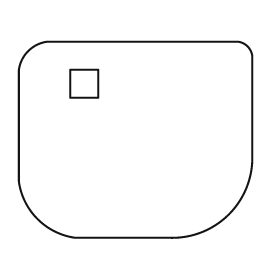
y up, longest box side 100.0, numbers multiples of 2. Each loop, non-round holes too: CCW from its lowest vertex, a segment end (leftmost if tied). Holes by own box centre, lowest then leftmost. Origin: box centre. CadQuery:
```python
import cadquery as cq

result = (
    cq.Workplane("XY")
    .moveTo(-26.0, -42.0)
    .lineTo(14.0, -42.0)
    .threePointArc((40.0, -32.0), (50.0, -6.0))
    .lineTo(50.0, 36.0)
    .threePointArc((48.0, 40.0), (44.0, 42.0))
    .lineTo(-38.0, 42.0)
    .threePointArc((-46.0, 38.0), (-50.0, 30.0))
    .lineTo(-50.0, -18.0)
    .threePointArc((-42.0, -34.0), (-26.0, -42.0))
    .close()
    .moveTo(-28.0, 18.0)
    .lineTo(-16.0, 18.0)
    .lineTo(-16.0, 30.0)
    .lineTo(-28.0, 30.0)
    .close()
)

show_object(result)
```